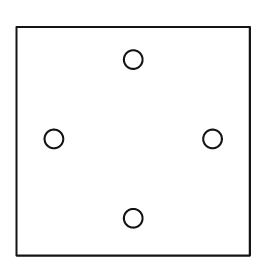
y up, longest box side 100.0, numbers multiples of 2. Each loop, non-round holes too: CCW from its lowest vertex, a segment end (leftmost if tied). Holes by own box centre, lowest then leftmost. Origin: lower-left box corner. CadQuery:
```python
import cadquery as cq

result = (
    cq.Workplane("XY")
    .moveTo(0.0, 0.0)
    .lineTo(100.0, 0.0)
    .lineTo(100.0, 98.0)
    .lineTo(0.0, 98.0)
    .close()
    .moveTo(50.0, 16.0)
    .circle(4.0)
    .moveTo(16.0, 50.0)
    .circle(4.0)
    .moveTo(84.0, 50.0)
    .circle(4.0)
    .moveTo(50.0, 84.0)
    .circle(4.0)
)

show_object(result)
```